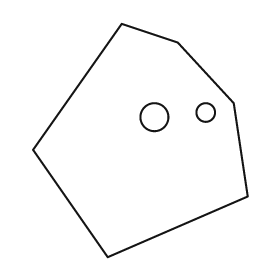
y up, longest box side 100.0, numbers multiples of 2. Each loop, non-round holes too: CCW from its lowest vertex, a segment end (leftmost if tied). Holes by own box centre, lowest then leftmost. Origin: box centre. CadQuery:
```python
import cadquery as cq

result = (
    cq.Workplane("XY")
    .moveTo(-14.0, -50.0)
    .lineTo(46.0, -24.0)
    .lineTo(40.0, 16.0)
    .lineTo(16.0, 42.0)
    .lineTo(-8.0, 50.0)
    .lineTo(-46.0, -4.0)
    .close()
    .moveTo(6.0, 10.0)
    .circle(6.0)
    .moveTo(28.0, 12.0)
    .circle(4.0)
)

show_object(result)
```